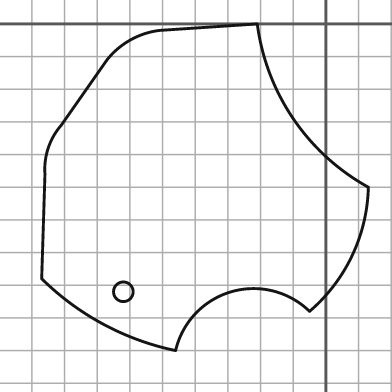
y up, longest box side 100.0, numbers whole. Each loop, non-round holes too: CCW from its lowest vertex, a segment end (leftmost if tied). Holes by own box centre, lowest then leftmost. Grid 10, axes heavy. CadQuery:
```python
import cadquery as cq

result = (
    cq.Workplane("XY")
    .moveTo(-46.0, -100.0)
    .threePointArc((-29.0, -82.0), (-5.0, -88.0))
    .threePointArc((8.0, -71.0), (13.0, -50.0))
    .threePointArc((-10.0, -29.0), (-21.0, 0.0))
    .lineTo(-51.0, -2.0)
    .threePointArc((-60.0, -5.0), (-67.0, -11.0))
    .lineTo(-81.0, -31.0)
    .threePointArc((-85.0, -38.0), (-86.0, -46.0))
    .lineTo(-87.0, -78.0)
    .threePointArc((-68.0, -92.0), (-46.0, -100.0))
    .close()
    .moveTo(-62.0, -82.0)
    .circle(3.0)
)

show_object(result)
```